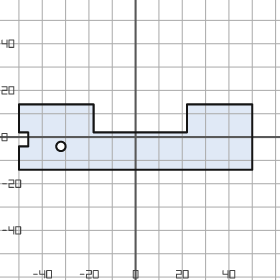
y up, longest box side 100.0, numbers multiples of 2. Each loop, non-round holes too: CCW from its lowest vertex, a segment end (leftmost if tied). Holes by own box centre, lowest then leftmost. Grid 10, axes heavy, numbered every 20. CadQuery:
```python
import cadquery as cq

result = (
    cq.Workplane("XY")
    .moveTo(-50.0, -14.0)
    .lineTo(50.0, -14.0)
    .lineTo(50.0, 14.0)
    .lineTo(22.0, 14.0)
    .lineTo(22.0, 2.0)
    .lineTo(-18.0, 2.0)
    .lineTo(-18.0, 14.0)
    .lineTo(-50.0, 14.0)
    .lineTo(-50.0, 2.0)
    .lineTo(-46.0, 2.0)
    .lineTo(-46.0, -4.0)
    .lineTo(-50.0, -4.0)
    .close()
    .moveTo(-32.0, -4.0)
    .circle(2.0)
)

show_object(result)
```